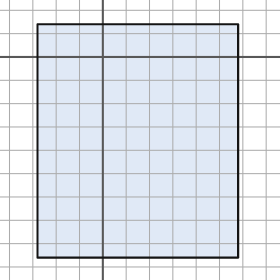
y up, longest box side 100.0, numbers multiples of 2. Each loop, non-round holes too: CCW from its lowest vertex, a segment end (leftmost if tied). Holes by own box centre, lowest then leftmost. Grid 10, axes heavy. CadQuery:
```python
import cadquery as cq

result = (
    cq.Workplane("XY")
    .moveTo(-28.0, -86.0)
    .lineTo(58.0, -86.0)
    .lineTo(58.0, 14.0)
    .lineTo(-28.0, 14.0)
    .close()
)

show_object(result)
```